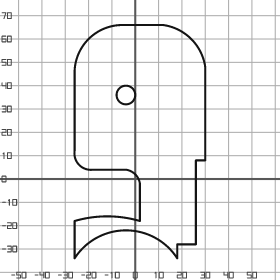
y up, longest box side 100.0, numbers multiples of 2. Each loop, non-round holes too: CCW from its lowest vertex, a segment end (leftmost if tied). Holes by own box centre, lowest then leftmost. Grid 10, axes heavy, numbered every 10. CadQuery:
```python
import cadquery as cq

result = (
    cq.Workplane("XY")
    .moveTo(-26.0, -34.0)
    .threePointArc((-4.0, -22.0), (18.0, -34.0))
    .lineTo(18.0, -28.0)
    .lineTo(26.0, -28.0)
    .lineTo(26.0, 8.0)
    .lineTo(30.0, 8.0)
    .lineTo(30.0, 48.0)
    .threePointArc((24.0, 60.0), (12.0, 66.0))
    .lineTo(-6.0, 66.0)
    .threePointArc((-20.0, 60.0), (-26.0, 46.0))
    .lineTo(-26.0, 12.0)
    .threePointArc((-24.0, 6.0), (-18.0, 4.0))
    .lineTo(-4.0, 4.0)
    .threePointArc((0.0, 2.0), (2.0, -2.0))
    .lineTo(2.0, -18.0)
    .threePointArc((-12.0, -16.0), (-26.0, -18.0))
    .close()
    .moveTo(-4.0, 36.0)
    .circle(4.0)
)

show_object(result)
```